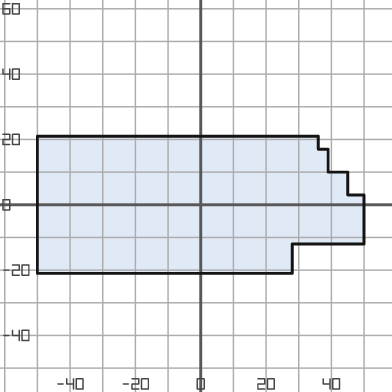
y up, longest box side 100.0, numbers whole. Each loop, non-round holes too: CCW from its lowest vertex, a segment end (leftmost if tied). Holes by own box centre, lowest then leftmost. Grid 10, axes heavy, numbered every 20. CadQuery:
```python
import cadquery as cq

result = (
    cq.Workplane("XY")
    .moveTo(-50.0, -21.0)
    .lineTo(28.0, -21.0)
    .lineTo(28.0, -12.0)
    .lineTo(50.0, -12.0)
    .lineTo(50.0, 3.0)
    .lineTo(45.0, 3.0)
    .lineTo(45.0, 10.0)
    .lineTo(39.0, 10.0)
    .lineTo(39.0, 17.0)
    .lineTo(36.0, 17.0)
    .lineTo(36.0, 21.0)
    .lineTo(-50.0, 21.0)
    .close()
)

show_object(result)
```